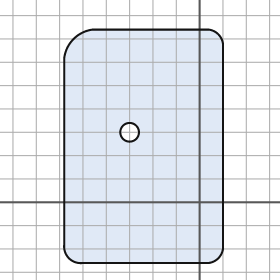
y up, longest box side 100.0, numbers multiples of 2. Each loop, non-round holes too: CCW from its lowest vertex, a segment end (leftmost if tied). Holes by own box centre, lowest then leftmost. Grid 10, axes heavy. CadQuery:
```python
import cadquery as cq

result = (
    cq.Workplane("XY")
    .moveTo(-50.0, -26.0)
    .lineTo(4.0, -26.0)
    .threePointArc((8.0, -24.0), (10.0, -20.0))
    .lineTo(10.0, 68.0)
    .threePointArc((8.0, 72.0), (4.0, 74.0))
    .lineTo(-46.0, 74.0)
    .threePointArc((-54.0, 70.0), (-58.0, 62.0))
    .lineTo(-58.0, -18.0)
    .threePointArc((-56.0, -24.0), (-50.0, -26.0))
    .close()
    .moveTo(-30.0, 30.0)
    .circle(4.0)
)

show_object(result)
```